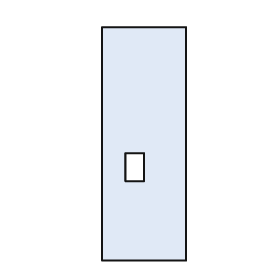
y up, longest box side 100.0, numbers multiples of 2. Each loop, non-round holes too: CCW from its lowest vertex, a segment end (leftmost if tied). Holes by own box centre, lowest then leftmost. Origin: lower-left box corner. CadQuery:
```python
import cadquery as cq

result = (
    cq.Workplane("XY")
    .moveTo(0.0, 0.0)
    .lineTo(36.0, 0.0)
    .lineTo(36.0, 100.0)
    .lineTo(0.0, 100.0)
    .close()
    .moveTo(10.0, 34.0)
    .lineTo(18.0, 34.0)
    .lineTo(18.0, 46.0)
    .lineTo(10.0, 46.0)
    .close()
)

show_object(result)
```